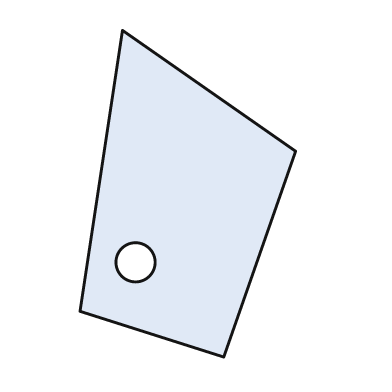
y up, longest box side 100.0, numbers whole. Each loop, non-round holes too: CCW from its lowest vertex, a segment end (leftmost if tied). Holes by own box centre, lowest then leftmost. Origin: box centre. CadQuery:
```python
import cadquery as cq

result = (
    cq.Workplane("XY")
    .moveTo(11.0, -50.0)
    .lineTo(33.0, 13.0)
    .lineTo(-20.0, 50.0)
    .lineTo(-33.0, -36.0)
    .close()
    .moveTo(-16.0, -21.0)
    .circle(6.0)
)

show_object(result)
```